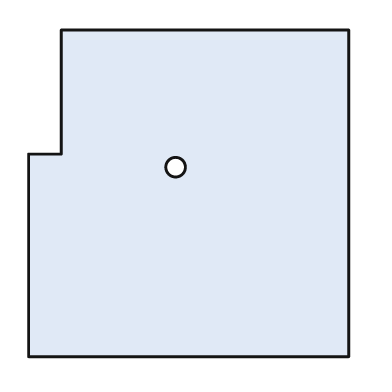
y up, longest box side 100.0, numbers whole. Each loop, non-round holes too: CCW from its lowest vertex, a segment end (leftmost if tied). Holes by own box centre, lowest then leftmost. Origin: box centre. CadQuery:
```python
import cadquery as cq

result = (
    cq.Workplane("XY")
    .moveTo(-49.0, -50.0)
    .lineTo(49.0, -50.0)
    .lineTo(49.0, 50.0)
    .lineTo(-39.0, 50.0)
    .lineTo(-39.0, 12.0)
    .lineTo(-49.0, 12.0)
    .close()
    .moveTo(-4.0, 8.0)
    .circle(3.0)
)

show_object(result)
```